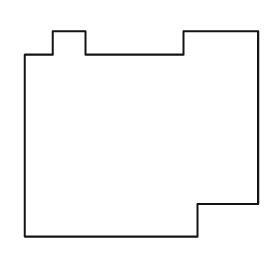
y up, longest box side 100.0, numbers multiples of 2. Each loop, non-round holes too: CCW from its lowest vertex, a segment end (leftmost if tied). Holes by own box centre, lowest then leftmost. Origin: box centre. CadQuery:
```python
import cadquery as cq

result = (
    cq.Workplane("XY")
    .moveTo(-50.0, -44.0)
    .lineTo(24.0, -44.0)
    .lineTo(24.0, -30.0)
    .lineTo(50.0, -30.0)
    .lineTo(50.0, 44.0)
    .lineTo(18.0, 44.0)
    .lineTo(18.0, 34.0)
    .lineTo(-24.0, 34.0)
    .lineTo(-24.0, 44.0)
    .lineTo(-38.0, 44.0)
    .lineTo(-38.0, 34.0)
    .lineTo(-50.0, 34.0)
    .close()
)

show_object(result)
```